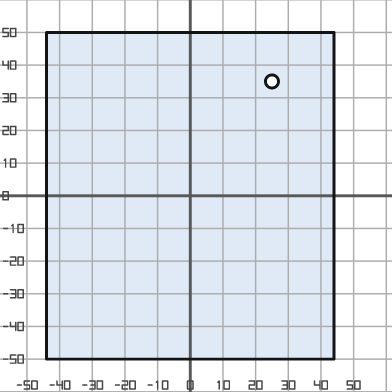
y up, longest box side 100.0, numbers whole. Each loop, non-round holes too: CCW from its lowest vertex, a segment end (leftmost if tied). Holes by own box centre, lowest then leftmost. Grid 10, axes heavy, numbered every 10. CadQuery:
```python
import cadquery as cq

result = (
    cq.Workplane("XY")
    .moveTo(-44.0, -50.0)
    .lineTo(44.0, -50.0)
    .lineTo(44.0, 50.0)
    .lineTo(-44.0, 50.0)
    .close()
    .moveTo(25.0, 35.0)
    .circle(2.0)
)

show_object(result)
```